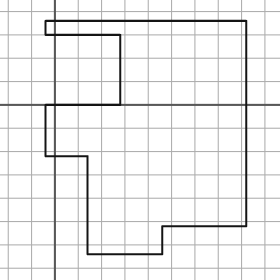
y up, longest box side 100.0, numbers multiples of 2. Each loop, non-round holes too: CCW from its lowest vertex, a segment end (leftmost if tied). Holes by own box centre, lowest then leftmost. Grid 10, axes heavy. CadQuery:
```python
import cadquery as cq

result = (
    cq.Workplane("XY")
    .moveTo(14.0, -64.0)
    .lineTo(46.0, -64.0)
    .lineTo(46.0, -52.0)
    .lineTo(82.0, -52.0)
    .lineTo(82.0, 36.0)
    .lineTo(-4.0, 36.0)
    .lineTo(-4.0, 30.0)
    .lineTo(28.0, 30.0)
    .lineTo(28.0, 0.0)
    .lineTo(-4.0, 0.0)
    .lineTo(-4.0, -22.0)
    .lineTo(14.0, -22.0)
    .close()
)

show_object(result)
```